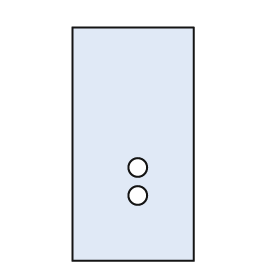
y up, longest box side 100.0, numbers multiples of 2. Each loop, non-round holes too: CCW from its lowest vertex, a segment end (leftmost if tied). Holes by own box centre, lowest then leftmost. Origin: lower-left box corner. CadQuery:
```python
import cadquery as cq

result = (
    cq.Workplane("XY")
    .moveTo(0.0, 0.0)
    .lineTo(52.0, 0.0)
    .lineTo(52.0, 100.0)
    .lineTo(0.0, 100.0)
    .close()
    .moveTo(28.0, 28.0)
    .circle(4.0)
    .moveTo(28.0, 40.0)
    .circle(4.0)
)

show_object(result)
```